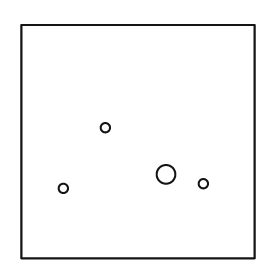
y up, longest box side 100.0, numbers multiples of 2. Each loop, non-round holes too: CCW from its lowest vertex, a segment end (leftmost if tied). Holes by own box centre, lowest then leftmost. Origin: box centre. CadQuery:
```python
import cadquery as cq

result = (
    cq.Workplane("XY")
    .moveTo(-50.0, -50.0)
    .lineTo(50.0, -50.0)
    .lineTo(50.0, 50.0)
    .lineTo(-50.0, 50.0)
    .close()
    .moveTo(-32.0, -20.0)
    .circle(2.0)
    .moveTo(28.0, -18.0)
    .circle(2.0)
    .moveTo(12.0, -14.0)
    .circle(4.0)
    .moveTo(-14.0, 6.0)
    .circle(2.0)
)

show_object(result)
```